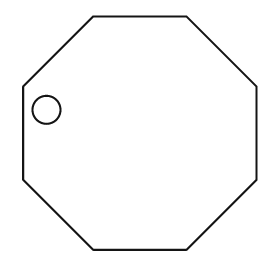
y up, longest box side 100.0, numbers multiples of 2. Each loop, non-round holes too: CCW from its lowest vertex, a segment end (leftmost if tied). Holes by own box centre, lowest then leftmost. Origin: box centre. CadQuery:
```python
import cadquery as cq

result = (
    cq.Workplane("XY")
    .moveTo(-20.0, -50.0)
    .lineTo(20.0, -50.0)
    .lineTo(50.0, -20.0)
    .lineTo(50.0, 20.0)
    .lineTo(20.0, 50.0)
    .lineTo(-20.0, 50.0)
    .lineTo(-50.0, 20.0)
    .lineTo(-50.0, -20.0)
    .close()
    .moveTo(-40.0, 10.0)
    .circle(6.0)
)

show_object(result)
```